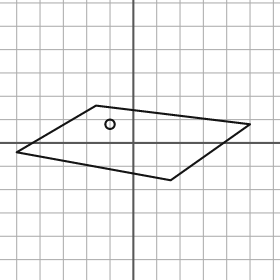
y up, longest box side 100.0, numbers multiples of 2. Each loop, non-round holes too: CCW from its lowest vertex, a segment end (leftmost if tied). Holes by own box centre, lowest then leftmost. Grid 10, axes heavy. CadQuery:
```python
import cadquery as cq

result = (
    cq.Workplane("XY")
    .moveTo(16.0, -16.0)
    .lineTo(50.0, 8.0)
    .lineTo(-16.0, 16.0)
    .lineTo(-50.0, -4.0)
    .close()
    .moveTo(-10.0, 8.0)
    .circle(2.0)
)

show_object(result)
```